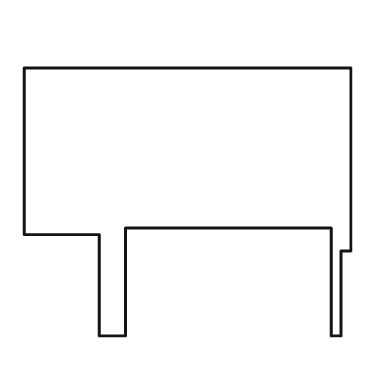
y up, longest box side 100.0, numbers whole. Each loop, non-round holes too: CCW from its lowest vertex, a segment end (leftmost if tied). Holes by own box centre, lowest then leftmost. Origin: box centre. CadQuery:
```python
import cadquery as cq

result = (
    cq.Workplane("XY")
    .moveTo(-27.0, -41.0)
    .lineTo(-19.0, -41.0)
    .lineTo(-19.0, -8.0)
    .lineTo(44.0, -8.0)
    .lineTo(44.0, -41.0)
    .lineTo(47.0, -41.0)
    .lineTo(47.0, -15.0)
    .lineTo(50.0, -15.0)
    .lineTo(50.0, 41.0)
    .lineTo(-50.0, 41.0)
    .lineTo(-50.0, -10.0)
    .lineTo(-27.0, -10.0)
    .close()
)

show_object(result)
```